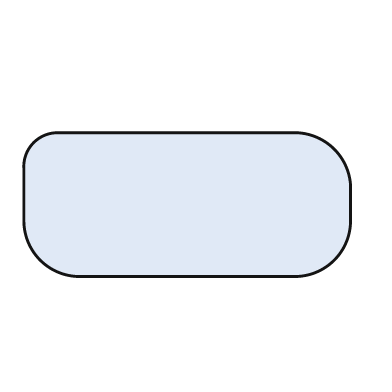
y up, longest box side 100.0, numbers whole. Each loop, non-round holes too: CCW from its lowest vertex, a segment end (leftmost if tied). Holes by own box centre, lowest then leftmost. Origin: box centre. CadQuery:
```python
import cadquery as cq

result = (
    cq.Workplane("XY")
    .moveTo(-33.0, -22.0)
    .lineTo(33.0, -22.0)
    .threePointArc((45.0, -17.0), (50.0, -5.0))
    .lineTo(50.0, 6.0)
    .threePointArc((45.0, 17.0), (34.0, 22.0))
    .lineTo(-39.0, 22.0)
    .threePointArc((-47.0, 19.0), (-50.0, 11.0))
    .lineTo(-50.0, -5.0)
    .threePointArc((-45.0, -17.0), (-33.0, -22.0))
    .close()
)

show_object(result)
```